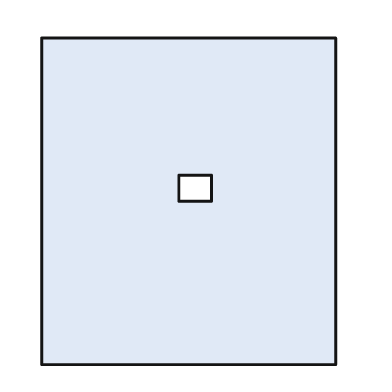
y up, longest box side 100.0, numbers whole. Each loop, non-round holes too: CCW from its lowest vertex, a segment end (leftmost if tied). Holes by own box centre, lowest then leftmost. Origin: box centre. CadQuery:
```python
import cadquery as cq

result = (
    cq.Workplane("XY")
    .moveTo(-45.0, -50.0)
    .lineTo(45.0, -50.0)
    .lineTo(45.0, 50.0)
    .lineTo(-45.0, 50.0)
    .close()
    .moveTo(-3.0, 0.0)
    .lineTo(7.0, 0.0)
    .lineTo(7.0, 8.0)
    .lineTo(-3.0, 8.0)
    .close()
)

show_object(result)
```